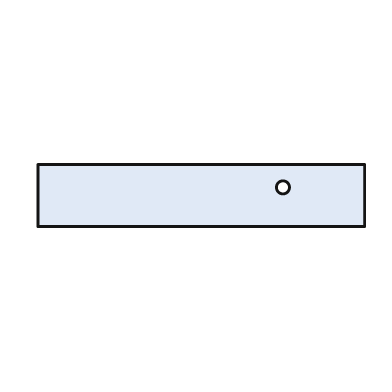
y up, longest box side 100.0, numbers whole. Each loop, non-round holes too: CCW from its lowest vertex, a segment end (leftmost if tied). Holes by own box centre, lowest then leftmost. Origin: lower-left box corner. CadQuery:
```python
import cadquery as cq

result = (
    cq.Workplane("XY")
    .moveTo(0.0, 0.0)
    .lineTo(100.0, 0.0)
    .lineTo(100.0, 19.0)
    .lineTo(0.0, 19.0)
    .close()
    .moveTo(75.0, 12.0)
    .circle(2.0)
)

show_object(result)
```